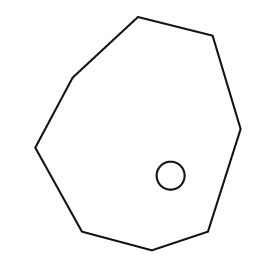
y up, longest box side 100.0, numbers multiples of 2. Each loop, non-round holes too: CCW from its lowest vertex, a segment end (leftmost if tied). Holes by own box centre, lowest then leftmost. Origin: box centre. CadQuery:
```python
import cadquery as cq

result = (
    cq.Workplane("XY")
    .moveTo(6.0, -50.0)
    .lineTo(30.0, -42.0)
    .lineTo(44.0, 2.0)
    .lineTo(32.0, 42.0)
    .lineTo(0.0, 50.0)
    .lineTo(-28.0, 24.0)
    .lineTo(-44.0, -6.0)
    .lineTo(-24.0, -42.0)
    .close()
    .moveTo(14.0, -18.0)
    .circle(6.0)
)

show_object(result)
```